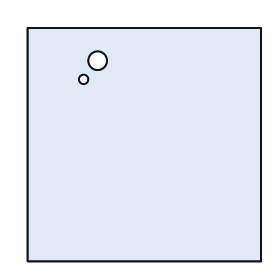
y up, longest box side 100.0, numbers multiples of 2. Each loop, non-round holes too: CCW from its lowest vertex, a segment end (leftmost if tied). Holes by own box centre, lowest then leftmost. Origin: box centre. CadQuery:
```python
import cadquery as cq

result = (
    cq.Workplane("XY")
    .moveTo(-50.0, -50.0)
    .lineTo(50.0, -50.0)
    .lineTo(50.0, 50.0)
    .lineTo(-50.0, 50.0)
    .close()
    .moveTo(-26.0, 28.0)
    .circle(2.0)
    .moveTo(-20.0, 36.0)
    .circle(4.0)
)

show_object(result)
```